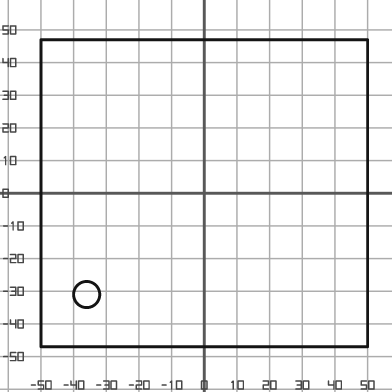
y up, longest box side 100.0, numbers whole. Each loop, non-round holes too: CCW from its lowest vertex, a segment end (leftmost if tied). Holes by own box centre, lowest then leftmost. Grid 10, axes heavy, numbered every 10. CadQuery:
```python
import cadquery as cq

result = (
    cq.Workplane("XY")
    .moveTo(-50.0, -47.0)
    .lineTo(50.0, -47.0)
    .lineTo(50.0, 47.0)
    .lineTo(-50.0, 47.0)
    .close()
    .moveTo(-36.0, -31.0)
    .circle(4.0)
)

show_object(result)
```